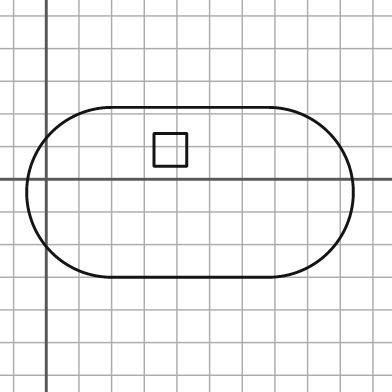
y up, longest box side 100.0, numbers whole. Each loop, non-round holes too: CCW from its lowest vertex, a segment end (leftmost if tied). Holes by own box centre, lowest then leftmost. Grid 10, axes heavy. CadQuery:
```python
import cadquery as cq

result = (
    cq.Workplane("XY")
    .moveTo(20.0, -30.0)
    .lineTo(68.0, -30.0)
    .threePointArc((94.0, -4.0), (68.0, 22.0))
    .lineTo(20.0, 22.0)
    .threePointArc((-6.0, -4.0), (20.0, -30.0))
    .close()
    .moveTo(33.0, 4.0)
    .lineTo(43.0, 4.0)
    .lineTo(43.0, 14.0)
    .lineTo(33.0, 14.0)
    .close()
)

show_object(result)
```